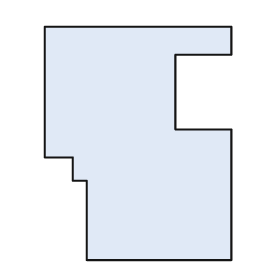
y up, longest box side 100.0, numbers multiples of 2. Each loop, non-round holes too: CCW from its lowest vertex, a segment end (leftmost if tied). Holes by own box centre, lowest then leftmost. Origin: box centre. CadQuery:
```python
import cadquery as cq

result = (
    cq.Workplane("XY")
    .moveTo(-22.0, -50.0)
    .lineTo(40.0, -50.0)
    .lineTo(40.0, 6.0)
    .lineTo(16.0, 6.0)
    .lineTo(16.0, 38.0)
    .lineTo(40.0, 38.0)
    .lineTo(40.0, 50.0)
    .lineTo(-40.0, 50.0)
    .lineTo(-40.0, -6.0)
    .lineTo(-28.0, -6.0)
    .lineTo(-28.0, -16.0)
    .lineTo(-22.0, -16.0)
    .close()
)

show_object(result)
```